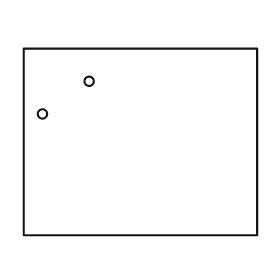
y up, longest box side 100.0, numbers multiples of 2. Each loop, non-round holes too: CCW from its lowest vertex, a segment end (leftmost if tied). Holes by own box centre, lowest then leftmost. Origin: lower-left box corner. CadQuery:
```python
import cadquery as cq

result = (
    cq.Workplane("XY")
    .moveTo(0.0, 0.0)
    .lineTo(100.0, 0.0)
    .lineTo(100.0, 80.0)
    .lineTo(0.0, 80.0)
    .close()
    .moveTo(8.0, 52.0)
    .circle(2.0)
    .moveTo(28.0, 66.0)
    .circle(2.0)
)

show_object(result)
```